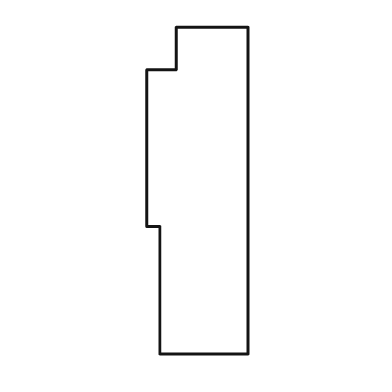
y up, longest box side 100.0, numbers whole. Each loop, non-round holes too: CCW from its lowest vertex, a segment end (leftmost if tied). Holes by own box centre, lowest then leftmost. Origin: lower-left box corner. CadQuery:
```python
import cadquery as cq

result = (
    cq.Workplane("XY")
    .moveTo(4.0, 0.0)
    .lineTo(31.0, 0.0)
    .lineTo(31.0, 100.0)
    .lineTo(9.0, 100.0)
    .lineTo(9.0, 87.0)
    .lineTo(0.0, 87.0)
    .lineTo(0.0, 39.0)
    .lineTo(4.0, 39.0)
    .close()
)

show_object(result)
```